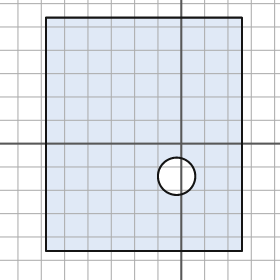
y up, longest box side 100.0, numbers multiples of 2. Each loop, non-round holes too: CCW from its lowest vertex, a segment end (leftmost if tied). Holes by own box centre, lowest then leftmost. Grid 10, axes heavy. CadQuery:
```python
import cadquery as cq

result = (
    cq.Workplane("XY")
    .moveTo(-58.0, -46.0)
    .lineTo(26.0, -46.0)
    .lineTo(26.0, 54.0)
    .lineTo(-58.0, 54.0)
    .close()
    .moveTo(-2.0, -14.0)
    .circle(8.0)
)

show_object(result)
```